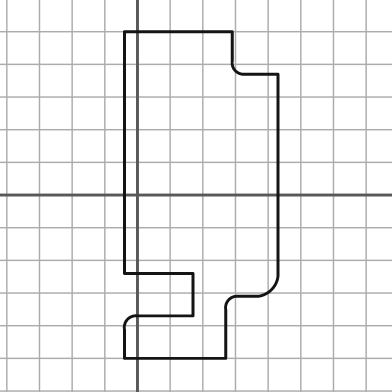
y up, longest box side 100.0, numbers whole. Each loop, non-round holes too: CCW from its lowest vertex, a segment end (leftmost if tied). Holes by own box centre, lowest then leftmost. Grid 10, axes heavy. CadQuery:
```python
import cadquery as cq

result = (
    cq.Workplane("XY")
    .moveTo(-4.0, -50.0)
    .lineTo(27.0, -50.0)
    .lineTo(27.0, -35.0)
    .threePointArc((28.0, -32.0), (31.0, -31.0))
    .lineTo(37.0, -31.0)
    .threePointArc((41.0, -29.0), (43.0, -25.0))
    .lineTo(43.0, 37.0)
    .lineTo(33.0, 37.0)
    .threePointArc((30.0, 38.0), (29.0, 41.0))
    .lineTo(29.0, 50.0)
    .lineTo(-4.0, 50.0)
    .lineTo(-4.0, -24.0)
    .lineTo(17.0, -24.0)
    .lineTo(17.0, -37.0)
    .lineTo(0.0, -37.0)
    .threePointArc((-3.0, -38.0), (-4.0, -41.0))
    .close()
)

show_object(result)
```